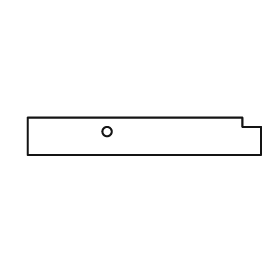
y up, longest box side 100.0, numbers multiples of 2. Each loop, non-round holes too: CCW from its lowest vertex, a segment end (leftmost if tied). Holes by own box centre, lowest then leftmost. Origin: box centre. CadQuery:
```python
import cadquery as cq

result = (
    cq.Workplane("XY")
    .moveTo(-50.0, -8.0)
    .lineTo(50.0, -8.0)
    .lineTo(50.0, 4.0)
    .lineTo(42.0, 4.0)
    .lineTo(42.0, 8.0)
    .lineTo(-50.0, 8.0)
    .close()
    .moveTo(-16.0, 2.0)
    .circle(2.0)
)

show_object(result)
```